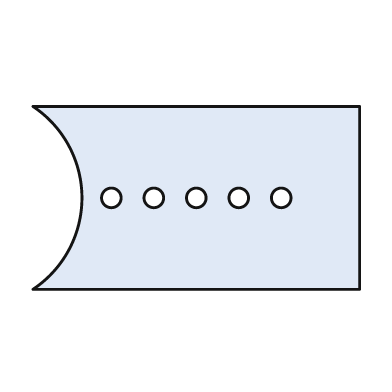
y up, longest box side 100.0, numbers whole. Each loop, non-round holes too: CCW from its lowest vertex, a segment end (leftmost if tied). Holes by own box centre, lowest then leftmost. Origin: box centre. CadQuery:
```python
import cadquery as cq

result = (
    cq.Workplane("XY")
    .moveTo(-50.0, -28.0)
    .lineTo(50.0, -28.0)
    .lineTo(50.0, 28.0)
    .lineTo(-50.0, 28.0)
    .threePointArc((-35.0, 0.0), (-50.0, -28.0))
    .close()
    .moveTo(-26.0, 0.0)
    .circle(3.0)
    .moveTo(-13.0, 0.0)
    .circle(3.0)
    .moveTo(0.0, 0.0)
    .circle(3.0)
    .moveTo(13.0, 0.0)
    .circle(3.0)
    .moveTo(26.0, 0.0)
    .circle(3.0)
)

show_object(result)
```